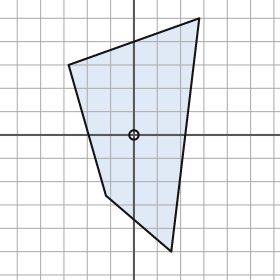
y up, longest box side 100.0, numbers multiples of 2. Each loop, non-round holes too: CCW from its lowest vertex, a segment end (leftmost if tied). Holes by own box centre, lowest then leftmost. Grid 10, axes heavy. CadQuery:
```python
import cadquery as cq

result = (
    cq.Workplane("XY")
    .moveTo(16.0, -50.0)
    .lineTo(28.0, 50.0)
    .lineTo(-28.0, 30.0)
    .lineTo(-12.0, -26.0)
    .close()
    .moveTo(0.0, 0.0)
    .circle(2.0)
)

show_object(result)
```